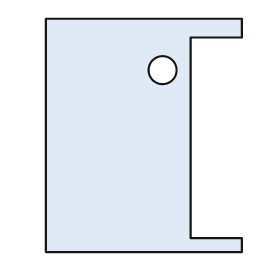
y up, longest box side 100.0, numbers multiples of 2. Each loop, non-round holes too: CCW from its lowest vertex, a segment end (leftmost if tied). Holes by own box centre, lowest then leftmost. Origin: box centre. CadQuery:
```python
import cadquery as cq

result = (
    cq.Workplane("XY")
    .moveTo(-42.0, -50.0)
    .lineTo(42.0, -50.0)
    .lineTo(42.0, -44.0)
    .lineTo(20.0, -44.0)
    .lineTo(20.0, 42.0)
    .lineTo(42.0, 42.0)
    .lineTo(42.0, 50.0)
    .lineTo(-42.0, 50.0)
    .close()
    .moveTo(8.0, 28.0)
    .circle(6.0)
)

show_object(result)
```